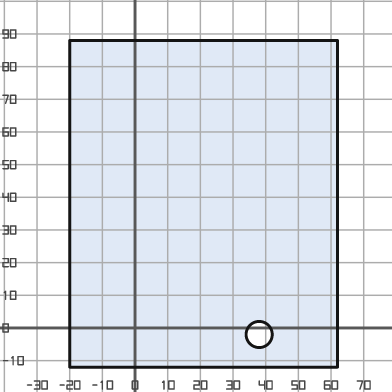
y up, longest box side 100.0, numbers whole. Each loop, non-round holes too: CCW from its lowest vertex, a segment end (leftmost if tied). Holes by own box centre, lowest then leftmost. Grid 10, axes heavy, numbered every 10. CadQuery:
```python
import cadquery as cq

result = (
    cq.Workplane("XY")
    .moveTo(-20.0, -12.0)
    .lineTo(62.0, -12.0)
    .lineTo(62.0, 88.0)
    .lineTo(-20.0, 88.0)
    .close()
    .moveTo(38.0, -2.0)
    .circle(4.0)
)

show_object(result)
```